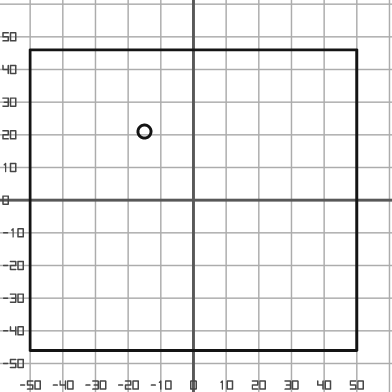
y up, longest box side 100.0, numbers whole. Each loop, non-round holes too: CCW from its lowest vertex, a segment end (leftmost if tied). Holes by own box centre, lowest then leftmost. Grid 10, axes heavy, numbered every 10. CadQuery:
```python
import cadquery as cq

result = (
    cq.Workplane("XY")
    .moveTo(-50.0, -46.0)
    .lineTo(50.0, -46.0)
    .lineTo(50.0, 46.0)
    .lineTo(-50.0, 46.0)
    .close()
    .moveTo(-15.0, 21.0)
    .circle(2.0)
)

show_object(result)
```